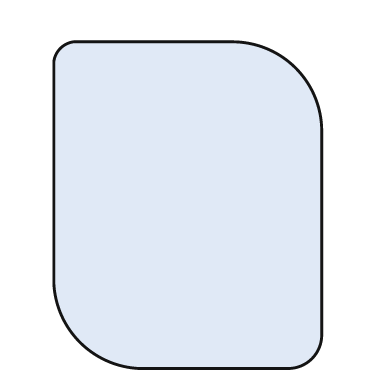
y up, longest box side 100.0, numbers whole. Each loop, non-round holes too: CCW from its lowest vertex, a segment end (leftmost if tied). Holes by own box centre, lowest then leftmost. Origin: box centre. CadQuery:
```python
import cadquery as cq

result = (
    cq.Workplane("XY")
    .moveTo(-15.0, -50.0)
    .lineTo(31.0, -50.0)
    .threePointArc((38.0, -47.0), (41.0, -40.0))
    .lineTo(41.0, 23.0)
    .threePointArc((33.0, 42.0), (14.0, 50.0))
    .lineTo(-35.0, 50.0)
    .threePointArc((-39.0, 48.0), (-41.0, 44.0))
    .lineTo(-41.0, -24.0)
    .threePointArc((-33.0, -42.0), (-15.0, -50.0))
    .close()
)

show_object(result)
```